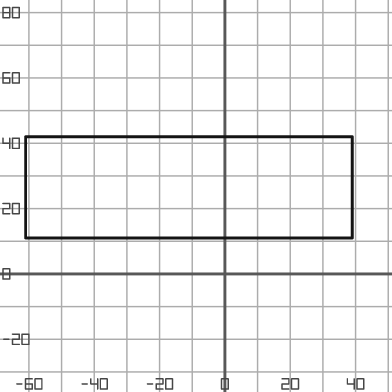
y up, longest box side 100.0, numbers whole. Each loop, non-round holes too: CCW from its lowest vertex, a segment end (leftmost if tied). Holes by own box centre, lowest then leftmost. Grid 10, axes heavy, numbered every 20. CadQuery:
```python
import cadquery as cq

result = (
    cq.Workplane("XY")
    .moveTo(-61.0, 11.0)
    .lineTo(39.0, 11.0)
    .lineTo(39.0, 42.0)
    .lineTo(-61.0, 42.0)
    .close()
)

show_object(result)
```